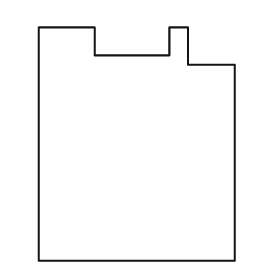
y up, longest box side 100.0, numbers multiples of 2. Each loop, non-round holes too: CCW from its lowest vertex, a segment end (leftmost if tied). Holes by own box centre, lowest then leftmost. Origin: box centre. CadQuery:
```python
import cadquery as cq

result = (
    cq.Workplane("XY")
    .moveTo(-42.0, -50.0)
    .lineTo(42.0, -50.0)
    .lineTo(42.0, 34.0)
    .lineTo(22.0, 34.0)
    .lineTo(22.0, 50.0)
    .lineTo(14.0, 50.0)
    .lineTo(14.0, 38.0)
    .lineTo(-18.0, 38.0)
    .lineTo(-18.0, 50.0)
    .lineTo(-42.0, 50.0)
    .close()
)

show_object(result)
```